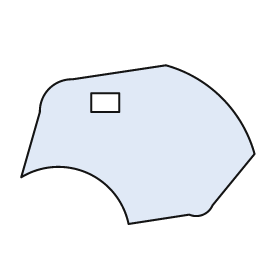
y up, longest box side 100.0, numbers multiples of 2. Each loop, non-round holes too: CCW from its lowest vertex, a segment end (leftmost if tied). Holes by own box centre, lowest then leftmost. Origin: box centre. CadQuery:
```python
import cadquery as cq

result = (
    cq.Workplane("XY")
    .moveTo(-4.0, -34.0)
    .lineTo(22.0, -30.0)
    .threePointArc((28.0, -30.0), (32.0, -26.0))
    .lineTo(50.0, -4.0)
    .threePointArc((36.0, 20.0), (12.0, 34.0))
    .lineTo(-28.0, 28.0)
    .threePointArc((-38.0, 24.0), (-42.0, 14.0))
    .lineTo(-50.0, -14.0)
    .threePointArc((-22.0, -12.0), (-4.0, -34.0))
    .close()
    .moveTo(-20.0, 14.0)
    .lineTo(-8.0, 14.0)
    .lineTo(-8.0, 22.0)
    .lineTo(-20.0, 22.0)
    .close()
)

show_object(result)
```